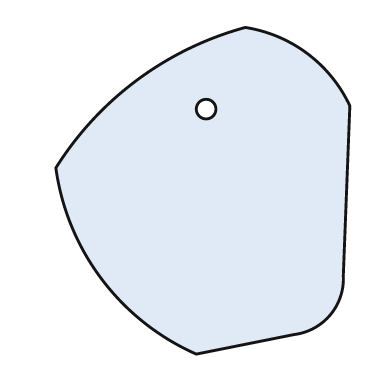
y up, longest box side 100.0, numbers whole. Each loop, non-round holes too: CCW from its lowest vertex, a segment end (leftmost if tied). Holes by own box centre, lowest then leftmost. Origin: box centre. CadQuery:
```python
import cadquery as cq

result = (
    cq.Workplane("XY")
    .moveTo(-2.0, -50.0)
    .lineTo(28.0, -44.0)
    .threePointArc((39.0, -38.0), (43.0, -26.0))
    .lineTo(45.0, 26.0)
    .threePointArc((32.0, 42.0), (13.0, 50.0))
    .threePointArc((-20.0, 34.0), (-45.0, 7.0))
    .threePointArc((-31.0, -27.0), (-2.0, -50.0))
    .close()
    .moveTo(1.0, 25.0)
    .circle(3.0)
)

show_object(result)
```